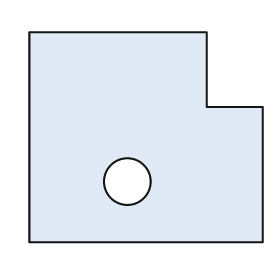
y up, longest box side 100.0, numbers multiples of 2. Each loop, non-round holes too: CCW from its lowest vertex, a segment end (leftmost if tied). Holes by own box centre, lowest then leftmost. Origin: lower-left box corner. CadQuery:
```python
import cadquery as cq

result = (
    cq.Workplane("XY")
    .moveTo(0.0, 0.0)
    .lineTo(100.0, 0.0)
    .lineTo(100.0, 58.0)
    .lineTo(76.0, 58.0)
    .lineTo(76.0, 90.0)
    .lineTo(0.0, 90.0)
    .close()
    .moveTo(42.0, 26.0)
    .circle(10.0)
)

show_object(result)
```